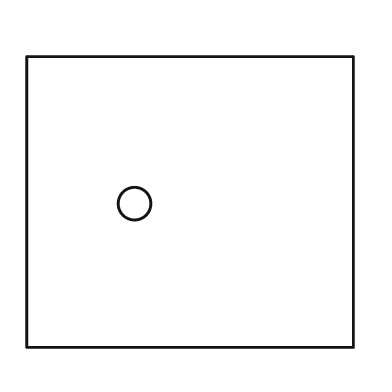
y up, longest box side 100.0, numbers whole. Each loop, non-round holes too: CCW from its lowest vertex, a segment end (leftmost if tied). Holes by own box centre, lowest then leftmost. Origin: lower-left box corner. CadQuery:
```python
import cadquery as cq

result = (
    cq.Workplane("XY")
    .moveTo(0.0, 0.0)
    .lineTo(100.0, 0.0)
    .lineTo(100.0, 89.0)
    .lineTo(0.0, 89.0)
    .close()
    .moveTo(33.0, 44.0)
    .circle(5.0)
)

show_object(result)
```